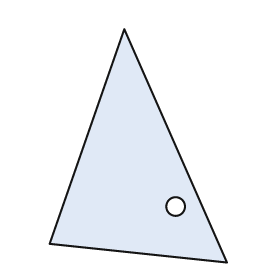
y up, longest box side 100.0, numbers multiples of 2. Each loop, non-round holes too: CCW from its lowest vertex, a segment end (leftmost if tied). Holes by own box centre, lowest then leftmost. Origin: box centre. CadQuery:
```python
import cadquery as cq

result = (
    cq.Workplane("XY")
    .moveTo(38.0, -50.0)
    .lineTo(-6.0, 50.0)
    .lineTo(-38.0, -42.0)
    .close()
    .moveTo(16.0, -26.0)
    .circle(4.0)
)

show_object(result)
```